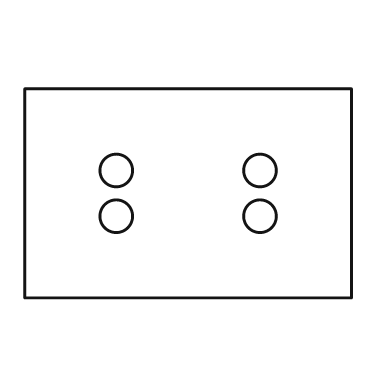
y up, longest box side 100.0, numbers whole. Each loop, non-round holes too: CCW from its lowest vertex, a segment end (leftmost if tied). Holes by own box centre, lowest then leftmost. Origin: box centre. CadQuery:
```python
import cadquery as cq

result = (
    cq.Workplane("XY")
    .moveTo(-50.0, -32.0)
    .lineTo(50.0, -32.0)
    .lineTo(50.0, 32.0)
    .lineTo(-50.0, 32.0)
    .close()
    .moveTo(-22.0, -7.0)
    .circle(5.0)
    .moveTo(22.0, -7.0)
    .circle(5.0)
    .moveTo(-22.0, 7.0)
    .circle(5.0)
    .moveTo(22.0, 7.0)
    .circle(5.0)
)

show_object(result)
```